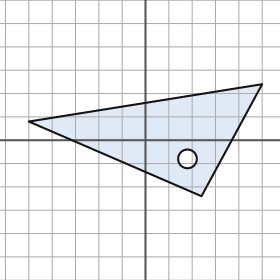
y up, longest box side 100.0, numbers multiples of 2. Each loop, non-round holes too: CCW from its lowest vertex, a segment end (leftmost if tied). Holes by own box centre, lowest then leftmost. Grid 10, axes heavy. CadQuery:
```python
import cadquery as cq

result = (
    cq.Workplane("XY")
    .moveTo(24.0, -24.0)
    .lineTo(50.0, 24.0)
    .lineTo(-50.0, 8.0)
    .close()
    .moveTo(18.0, -8.0)
    .circle(4.0)
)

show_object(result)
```